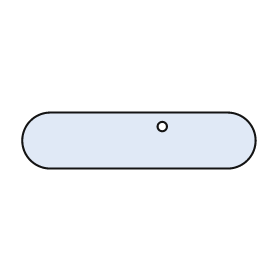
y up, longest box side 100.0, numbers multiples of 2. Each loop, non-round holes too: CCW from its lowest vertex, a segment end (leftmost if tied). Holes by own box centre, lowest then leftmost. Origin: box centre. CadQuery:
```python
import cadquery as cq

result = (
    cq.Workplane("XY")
    .moveTo(-38.0, -12.0)
    .lineTo(38.0, -12.0)
    .threePointArc((50.0, 0.0), (38.0, 12.0))
    .lineTo(-38.0, 12.0)
    .threePointArc((-50.0, 0.0), (-38.0, -12.0))
    .close()
    .moveTo(10.0, 6.0)
    .circle(2.0)
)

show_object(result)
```